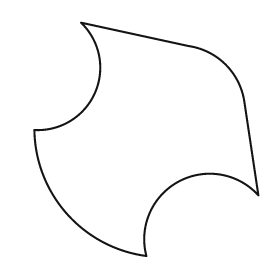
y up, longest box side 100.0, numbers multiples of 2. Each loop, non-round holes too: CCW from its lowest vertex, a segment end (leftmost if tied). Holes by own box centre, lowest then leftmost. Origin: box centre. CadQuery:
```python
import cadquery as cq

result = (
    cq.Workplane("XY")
    .moveTo(0.0, -50.0)
    .threePointArc((14.0, -18.0), (48.0, -24.0))
    .lineTo(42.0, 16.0)
    .threePointArc((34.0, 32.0), (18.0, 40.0))
    .lineTo(-28.0, 50.0)
    .threePointArc((-22.0, 20.0), (-48.0, 4.0))
    .threePointArc((-34.0, -32.0), (0.0, -50.0))
    .close()
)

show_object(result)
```